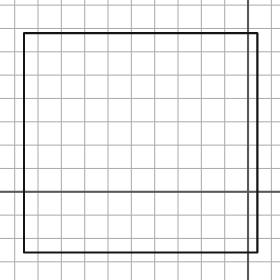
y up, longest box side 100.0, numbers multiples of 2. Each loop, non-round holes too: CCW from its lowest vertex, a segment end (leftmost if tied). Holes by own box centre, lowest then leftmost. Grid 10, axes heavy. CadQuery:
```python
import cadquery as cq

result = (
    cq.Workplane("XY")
    .moveTo(-96.0, -26.0)
    .lineTo(4.0, -26.0)
    .lineTo(4.0, 68.0)
    .lineTo(-96.0, 68.0)
    .close()
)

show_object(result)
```